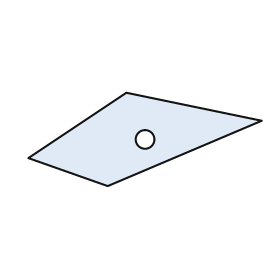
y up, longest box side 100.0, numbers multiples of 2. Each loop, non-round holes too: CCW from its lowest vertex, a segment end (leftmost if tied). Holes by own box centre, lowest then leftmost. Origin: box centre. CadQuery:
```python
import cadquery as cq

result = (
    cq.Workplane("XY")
    .moveTo(-16.0, -20.0)
    .lineTo(50.0, 8.0)
    .lineTo(-8.0, 20.0)
    .lineTo(-50.0, -8.0)
    .close()
    .moveTo(0.0, 0.0)
    .circle(4.0)
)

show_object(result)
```